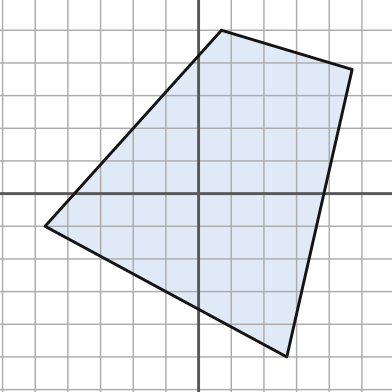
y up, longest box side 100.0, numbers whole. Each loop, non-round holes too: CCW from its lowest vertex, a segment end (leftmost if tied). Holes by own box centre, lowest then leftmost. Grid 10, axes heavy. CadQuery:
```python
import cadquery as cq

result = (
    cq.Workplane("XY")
    .moveTo(27.0, -50.0)
    .lineTo(47.0, 38.0)
    .lineTo(7.0, 50.0)
    .lineTo(-47.0, -10.0)
    .close()
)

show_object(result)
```